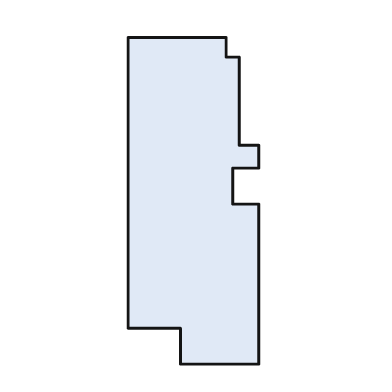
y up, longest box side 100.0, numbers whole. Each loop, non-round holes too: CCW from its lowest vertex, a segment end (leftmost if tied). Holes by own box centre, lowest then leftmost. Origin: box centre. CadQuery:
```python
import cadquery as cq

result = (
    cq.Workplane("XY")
    .moveTo(-4.0, -50.0)
    .lineTo(20.0, -50.0)
    .lineTo(20.0, -1.0)
    .lineTo(12.0, -1.0)
    .lineTo(12.0, 10.0)
    .lineTo(20.0, 10.0)
    .lineTo(20.0, 17.0)
    .lineTo(14.0, 17.0)
    .lineTo(14.0, 44.0)
    .lineTo(10.0, 44.0)
    .lineTo(10.0, 50.0)
    .lineTo(-20.0, 50.0)
    .lineTo(-20.0, -39.0)
    .lineTo(-4.0, -39.0)
    .close()
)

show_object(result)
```